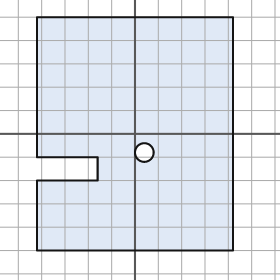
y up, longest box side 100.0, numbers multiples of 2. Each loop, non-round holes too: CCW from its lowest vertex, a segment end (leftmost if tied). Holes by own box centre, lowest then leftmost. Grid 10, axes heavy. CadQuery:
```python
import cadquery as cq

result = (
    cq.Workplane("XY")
    .moveTo(-42.0, -50.0)
    .lineTo(42.0, -50.0)
    .lineTo(42.0, 50.0)
    .lineTo(-42.0, 50.0)
    .lineTo(-42.0, -10.0)
    .lineTo(-16.0, -10.0)
    .lineTo(-16.0, -20.0)
    .lineTo(-42.0, -20.0)
    .close()
    .moveTo(4.0, -8.0)
    .circle(4.0)
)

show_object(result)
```